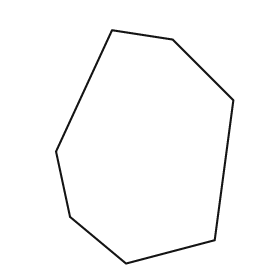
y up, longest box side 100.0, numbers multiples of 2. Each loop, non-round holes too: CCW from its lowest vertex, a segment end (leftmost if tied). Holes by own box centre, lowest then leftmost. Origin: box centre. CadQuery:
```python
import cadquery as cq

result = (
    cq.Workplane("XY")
    .moveTo(-8.0, -50.0)
    .lineTo(30.0, -40.0)
    .lineTo(38.0, 20.0)
    .lineTo(12.0, 46.0)
    .lineTo(-14.0, 50.0)
    .lineTo(-38.0, -2.0)
    .lineTo(-32.0, -30.0)
    .close()
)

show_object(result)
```